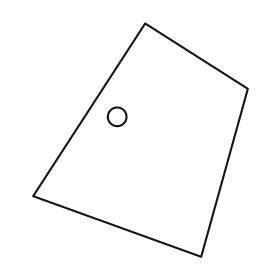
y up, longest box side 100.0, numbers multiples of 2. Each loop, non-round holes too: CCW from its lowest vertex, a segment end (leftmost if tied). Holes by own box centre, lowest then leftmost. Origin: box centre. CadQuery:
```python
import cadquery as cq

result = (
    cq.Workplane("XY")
    .moveTo(26.0, -50.0)
    .lineTo(46.0, 22.0)
    .lineTo(2.0, 50.0)
    .lineTo(-46.0, -24.0)
    .close()
    .moveTo(-10.0, 10.0)
    .circle(4.0)
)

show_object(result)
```